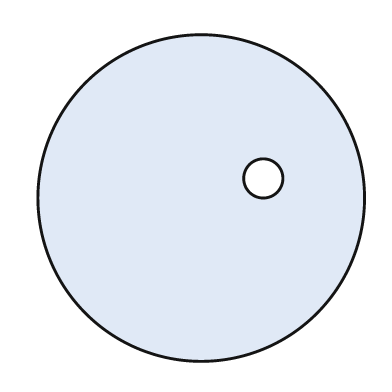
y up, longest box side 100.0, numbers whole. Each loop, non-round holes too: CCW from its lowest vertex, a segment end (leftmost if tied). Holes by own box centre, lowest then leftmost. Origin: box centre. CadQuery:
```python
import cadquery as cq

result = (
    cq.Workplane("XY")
    .moveTo(0.0, 0.0)
    .circle(50.0)
    .moveTo(19.0, 6.0)
    .circle(6.0)
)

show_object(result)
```